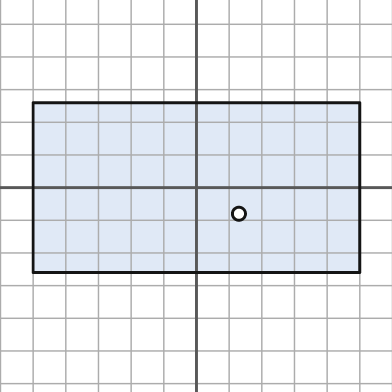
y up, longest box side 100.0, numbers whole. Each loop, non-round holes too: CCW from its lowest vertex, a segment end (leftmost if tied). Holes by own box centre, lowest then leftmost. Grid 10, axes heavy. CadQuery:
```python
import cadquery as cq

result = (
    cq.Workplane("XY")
    .moveTo(-50.0, -26.0)
    .lineTo(50.0, -26.0)
    .lineTo(50.0, 26.0)
    .lineTo(-50.0, 26.0)
    .close()
    .moveTo(13.0, -8.0)
    .circle(2.0)
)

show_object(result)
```